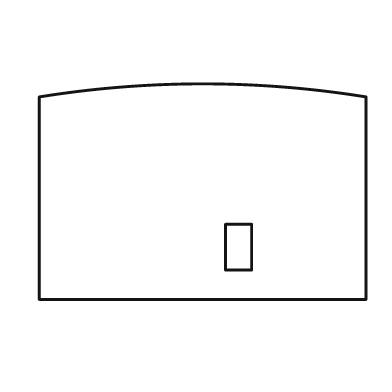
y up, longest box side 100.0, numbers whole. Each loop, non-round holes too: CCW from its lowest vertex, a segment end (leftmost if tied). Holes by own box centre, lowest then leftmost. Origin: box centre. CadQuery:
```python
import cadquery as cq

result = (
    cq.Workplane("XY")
    .moveTo(-50.0, -33.0)
    .lineTo(50.0, -33.0)
    .lineTo(50.0, 29.0)
    .threePointArc((0.0, 33.0), (-50.0, 29.0))
    .close()
    .moveTo(7.0, -24.0)
    .lineTo(15.0, -24.0)
    .lineTo(15.0, -10.0)
    .lineTo(7.0, -10.0)
    .close()
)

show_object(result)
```